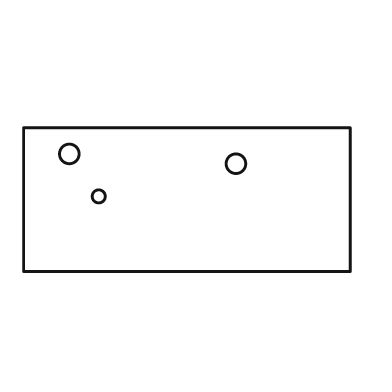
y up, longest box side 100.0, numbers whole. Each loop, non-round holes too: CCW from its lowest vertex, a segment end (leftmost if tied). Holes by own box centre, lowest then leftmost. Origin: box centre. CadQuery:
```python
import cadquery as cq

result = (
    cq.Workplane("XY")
    .moveTo(-50.0, -22.0)
    .lineTo(50.0, -22.0)
    .lineTo(50.0, 22.0)
    .lineTo(-50.0, 22.0)
    .close()
    .moveTo(-27.0, 1.0)
    .circle(2.0)
    .moveTo(15.0, 11.0)
    .circle(3.0)
    .moveTo(-36.0, 14.0)
    .circle(3.0)
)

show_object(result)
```